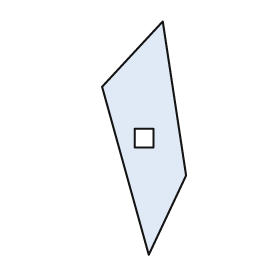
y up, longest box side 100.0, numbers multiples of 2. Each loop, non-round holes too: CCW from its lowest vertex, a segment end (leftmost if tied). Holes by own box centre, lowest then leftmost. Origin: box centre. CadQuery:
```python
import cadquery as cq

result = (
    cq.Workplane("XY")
    .moveTo(2.0, -50.0)
    .lineTo(18.0, -16.0)
    .lineTo(8.0, 50.0)
    .lineTo(-18.0, 22.0)
    .close()
    .moveTo(-4.0, -4.0)
    .lineTo(4.0, -4.0)
    .lineTo(4.0, 4.0)
    .lineTo(-4.0, 4.0)
    .close()
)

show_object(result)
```